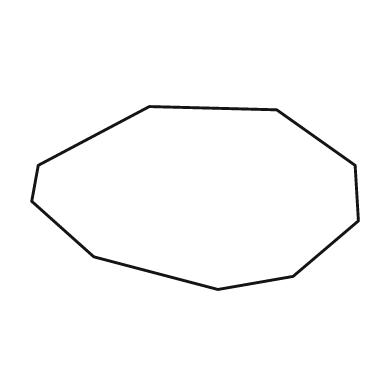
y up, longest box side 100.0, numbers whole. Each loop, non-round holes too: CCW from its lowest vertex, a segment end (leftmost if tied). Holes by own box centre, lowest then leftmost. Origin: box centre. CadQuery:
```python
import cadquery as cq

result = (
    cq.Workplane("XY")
    .moveTo(7.0, -28.0)
    .lineTo(30.0, -24.0)
    .lineTo(50.0, -7.0)
    .lineTo(49.0, 10.0)
    .lineTo(25.0, 27.0)
    .lineTo(-14.0, 28.0)
    .lineTo(-48.0, 10.0)
    .lineTo(-50.0, -1.0)
    .lineTo(-31.0, -18.0)
    .close()
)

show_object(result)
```